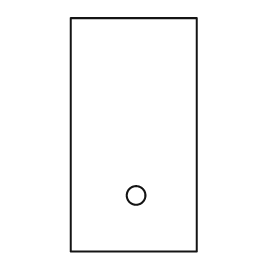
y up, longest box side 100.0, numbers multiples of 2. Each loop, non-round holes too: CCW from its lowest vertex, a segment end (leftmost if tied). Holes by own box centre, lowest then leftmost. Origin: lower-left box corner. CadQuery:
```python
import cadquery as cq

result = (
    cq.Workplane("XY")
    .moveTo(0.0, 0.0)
    .lineTo(54.0, 0.0)
    .lineTo(54.0, 100.0)
    .lineTo(0.0, 100.0)
    .close()
    .moveTo(28.0, 24.0)
    .circle(4.0)
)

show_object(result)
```